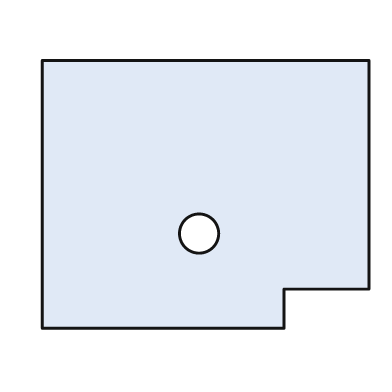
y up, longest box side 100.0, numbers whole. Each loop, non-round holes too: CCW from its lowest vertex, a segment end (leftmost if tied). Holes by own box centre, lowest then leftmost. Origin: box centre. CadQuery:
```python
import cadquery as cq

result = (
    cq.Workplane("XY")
    .moveTo(-50.0, -41.0)
    .lineTo(24.0, -41.0)
    .lineTo(24.0, -29.0)
    .lineTo(50.0, -29.0)
    .lineTo(50.0, 41.0)
    .lineTo(-50.0, 41.0)
    .close()
    .moveTo(-2.0, -12.0)
    .circle(6.0)
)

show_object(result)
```